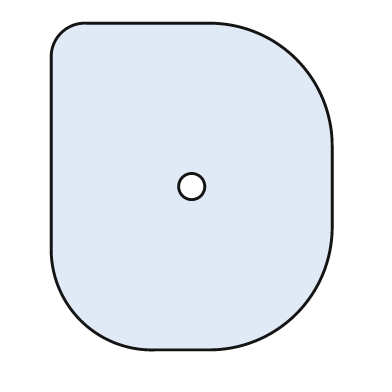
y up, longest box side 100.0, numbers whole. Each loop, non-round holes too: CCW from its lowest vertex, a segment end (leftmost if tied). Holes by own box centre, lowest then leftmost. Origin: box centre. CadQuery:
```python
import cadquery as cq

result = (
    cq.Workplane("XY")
    .moveTo(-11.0, -50.0)
    .lineTo(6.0, -50.0)
    .threePointArc((32.0, -39.0), (43.0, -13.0))
    .lineTo(43.0, 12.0)
    .threePointArc((32.0, 39.0), (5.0, 50.0))
    .lineTo(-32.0, 50.0)
    .threePointArc((-40.0, 47.0), (-43.0, 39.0))
    .lineTo(-43.0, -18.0)
    .threePointArc((-34.0, -41.0), (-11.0, -50.0))
    .close()
    .moveTo(0.0, 0.0)
    .circle(4.0)
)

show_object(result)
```